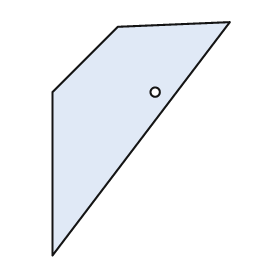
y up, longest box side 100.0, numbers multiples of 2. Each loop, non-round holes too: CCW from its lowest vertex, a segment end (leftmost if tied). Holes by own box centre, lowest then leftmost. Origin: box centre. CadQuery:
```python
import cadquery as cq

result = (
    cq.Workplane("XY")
    .moveTo(-38.0, -50.0)
    .lineTo(38.0, 50.0)
    .lineTo(-10.0, 48.0)
    .lineTo(-38.0, 20.0)
    .close()
    .moveTo(6.0, 20.0)
    .circle(2.0)
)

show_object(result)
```